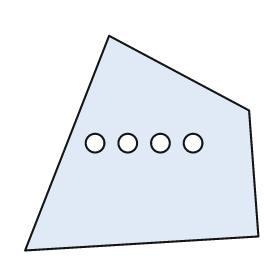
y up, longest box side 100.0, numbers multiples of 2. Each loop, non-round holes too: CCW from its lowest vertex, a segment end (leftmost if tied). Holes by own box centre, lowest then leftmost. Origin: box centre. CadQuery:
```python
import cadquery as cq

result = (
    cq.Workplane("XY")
    .moveTo(-50.0, -46.0)
    .lineTo(50.0, -40.0)
    .lineTo(46.0, 14.0)
    .lineTo(-14.0, 46.0)
    .close()
    .moveTo(-20.0, 0.0)
    .circle(4.0)
    .moveTo(-6.0, 0.0)
    .circle(4.0)
    .moveTo(8.0, 0.0)
    .circle(4.0)
    .moveTo(22.0, 0.0)
    .circle(4.0)
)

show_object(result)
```